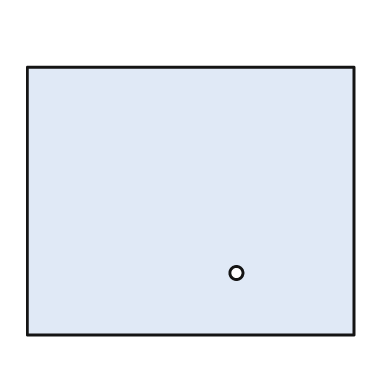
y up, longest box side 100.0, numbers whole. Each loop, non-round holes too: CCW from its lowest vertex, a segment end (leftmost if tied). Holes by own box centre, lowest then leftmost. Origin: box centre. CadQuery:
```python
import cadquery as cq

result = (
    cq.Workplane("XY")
    .moveTo(-50.0, -41.0)
    .lineTo(50.0, -41.0)
    .lineTo(50.0, 41.0)
    .lineTo(-50.0, 41.0)
    .close()
    .moveTo(14.0, -22.0)
    .circle(2.0)
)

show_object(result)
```